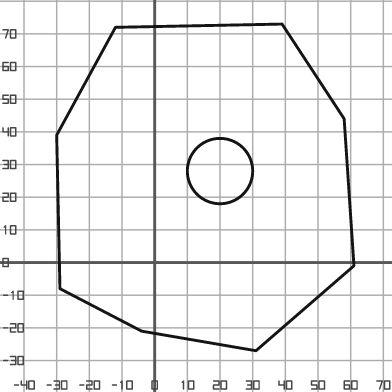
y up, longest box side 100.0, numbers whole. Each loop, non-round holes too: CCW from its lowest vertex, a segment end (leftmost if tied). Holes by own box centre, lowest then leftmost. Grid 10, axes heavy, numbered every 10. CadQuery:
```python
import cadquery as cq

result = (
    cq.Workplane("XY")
    .moveTo(31.0, -27.0)
    .lineTo(61.0, -1.0)
    .lineTo(58.0, 44.0)
    .lineTo(39.0, 73.0)
    .lineTo(-12.0, 72.0)
    .lineTo(-30.0, 39.0)
    .lineTo(-29.0, -8.0)
    .lineTo(-4.0, -21.0)
    .close()
    .moveTo(20.0, 28.0)
    .circle(10.0)
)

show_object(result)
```